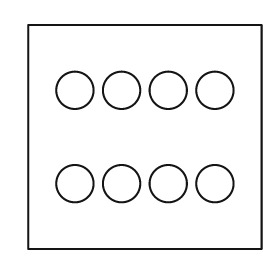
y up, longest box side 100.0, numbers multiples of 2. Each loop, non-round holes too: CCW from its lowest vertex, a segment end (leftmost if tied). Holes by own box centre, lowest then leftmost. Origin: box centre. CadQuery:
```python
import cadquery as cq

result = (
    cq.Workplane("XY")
    .moveTo(-50.0, -48.0)
    .lineTo(50.0, -48.0)
    .lineTo(50.0, 48.0)
    .lineTo(-50.0, 48.0)
    .close()
    .moveTo(-30.0, -20.0)
    .circle(8.0)
    .moveTo(-10.0, -20.0)
    .circle(8.0)
    .moveTo(10.0, -20.0)
    .circle(8.0)
    .moveTo(30.0, -20.0)
    .circle(8.0)
    .moveTo(-30.0, 20.0)
    .circle(8.0)
    .moveTo(-10.0, 20.0)
    .circle(8.0)
    .moveTo(10.0, 20.0)
    .circle(8.0)
    .moveTo(30.0, 20.0)
    .circle(8.0)
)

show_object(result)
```